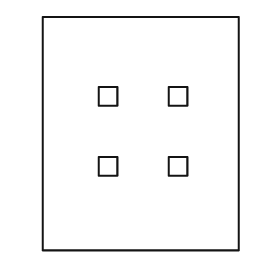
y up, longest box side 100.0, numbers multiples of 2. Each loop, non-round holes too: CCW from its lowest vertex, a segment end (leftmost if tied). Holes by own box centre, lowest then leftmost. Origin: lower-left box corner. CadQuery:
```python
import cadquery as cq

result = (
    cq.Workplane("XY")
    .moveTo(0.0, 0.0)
    .lineTo(84.0, 0.0)
    .lineTo(84.0, 100.0)
    .lineTo(0.0, 100.0)
    .close()
    .moveTo(24.0, 32.0)
    .lineTo(32.0, 32.0)
    .lineTo(32.0, 40.0)
    .lineTo(24.0, 40.0)
    .close()
    .moveTo(54.0, 32.0)
    .lineTo(62.0, 32.0)
    .lineTo(62.0, 40.0)
    .lineTo(54.0, 40.0)
    .close()
    .moveTo(24.0, 62.0)
    .lineTo(32.0, 62.0)
    .lineTo(32.0, 70.0)
    .lineTo(24.0, 70.0)
    .close()
    .moveTo(54.0, 62.0)
    .lineTo(62.0, 62.0)
    .lineTo(62.0, 70.0)
    .lineTo(54.0, 70.0)
    .close()
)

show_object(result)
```